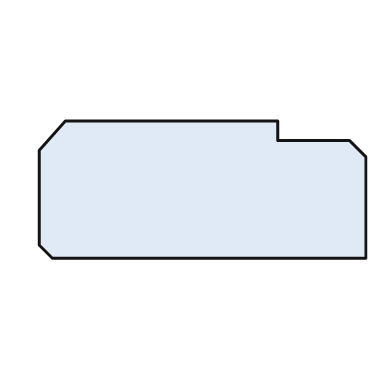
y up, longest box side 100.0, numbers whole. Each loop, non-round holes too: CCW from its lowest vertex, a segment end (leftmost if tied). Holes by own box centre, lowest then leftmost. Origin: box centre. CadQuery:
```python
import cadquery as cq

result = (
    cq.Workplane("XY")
    .moveTo(-46.0, -21.0)
    .lineTo(50.0, -21.0)
    .lineTo(50.0, 10.0)
    .lineTo(45.0, 15.0)
    .lineTo(23.0, 15.0)
    .lineTo(23.0, 21.0)
    .lineTo(-42.0, 21.0)
    .lineTo(-50.0, 12.0)
    .lineTo(-50.0, -17.0)
    .close()
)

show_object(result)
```